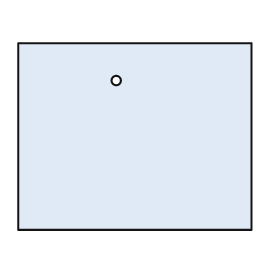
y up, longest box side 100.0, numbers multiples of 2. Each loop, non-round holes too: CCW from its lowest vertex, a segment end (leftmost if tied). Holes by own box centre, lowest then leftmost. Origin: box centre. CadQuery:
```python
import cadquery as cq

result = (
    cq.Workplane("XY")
    .moveTo(-50.0, -40.0)
    .lineTo(50.0, -40.0)
    .lineTo(50.0, 40.0)
    .lineTo(-50.0, 40.0)
    .close()
    .moveTo(-8.0, 24.0)
    .circle(2.0)
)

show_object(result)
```